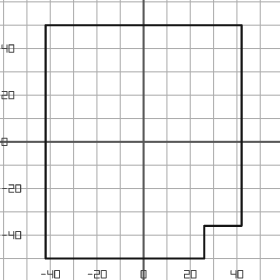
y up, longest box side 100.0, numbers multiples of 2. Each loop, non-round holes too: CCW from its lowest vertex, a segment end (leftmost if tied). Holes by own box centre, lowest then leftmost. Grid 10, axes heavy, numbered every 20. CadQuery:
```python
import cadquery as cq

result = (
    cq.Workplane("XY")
    .moveTo(-42.0, -50.0)
    .lineTo(26.0, -50.0)
    .lineTo(26.0, -36.0)
    .lineTo(42.0, -36.0)
    .lineTo(42.0, 50.0)
    .lineTo(-42.0, 50.0)
    .close()
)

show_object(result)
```